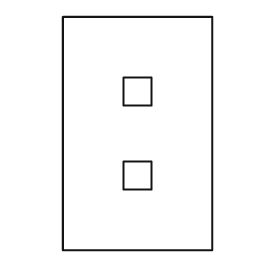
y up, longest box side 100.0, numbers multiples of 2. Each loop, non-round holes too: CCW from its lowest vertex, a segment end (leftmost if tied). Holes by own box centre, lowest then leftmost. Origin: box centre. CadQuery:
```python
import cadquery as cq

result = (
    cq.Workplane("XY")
    .moveTo(-32.0, -50.0)
    .lineTo(32.0, -50.0)
    .lineTo(32.0, 50.0)
    .lineTo(-32.0, 50.0)
    .close()
    .moveTo(-6.0, -24.0)
    .lineTo(6.0, -24.0)
    .lineTo(6.0, -12.0)
    .lineTo(-6.0, -12.0)
    .close()
    .moveTo(-6.0, 12.0)
    .lineTo(6.0, 12.0)
    .lineTo(6.0, 24.0)
    .lineTo(-6.0, 24.0)
    .close()
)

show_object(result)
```